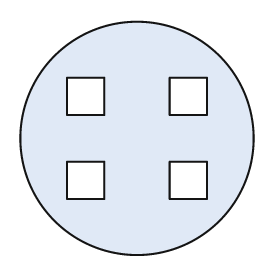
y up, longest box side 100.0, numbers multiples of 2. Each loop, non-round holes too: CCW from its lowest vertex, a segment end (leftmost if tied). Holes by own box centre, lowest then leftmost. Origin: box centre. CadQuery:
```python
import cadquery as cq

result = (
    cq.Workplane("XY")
    .moveTo(0.0, 0.0)
    .circle(50.0)
    .moveTo(-30.0, -26.0)
    .lineTo(-14.0, -26.0)
    .lineTo(-14.0, -10.0)
    .lineTo(-30.0, -10.0)
    .close()
    .moveTo(14.0, -26.0)
    .lineTo(30.0, -26.0)
    .lineTo(30.0, -10.0)
    .lineTo(14.0, -10.0)
    .close()
    .moveTo(-30.0, 10.0)
    .lineTo(-14.0, 10.0)
    .lineTo(-14.0, 26.0)
    .lineTo(-30.0, 26.0)
    .close()
    .moveTo(14.0, 10.0)
    .lineTo(30.0, 10.0)
    .lineTo(30.0, 26.0)
    .lineTo(14.0, 26.0)
    .close()
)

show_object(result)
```